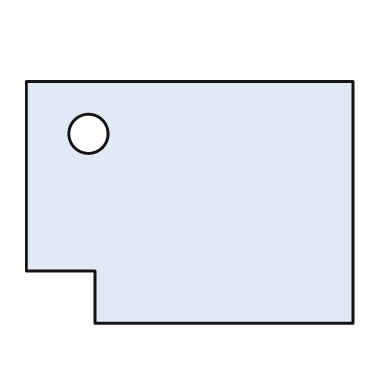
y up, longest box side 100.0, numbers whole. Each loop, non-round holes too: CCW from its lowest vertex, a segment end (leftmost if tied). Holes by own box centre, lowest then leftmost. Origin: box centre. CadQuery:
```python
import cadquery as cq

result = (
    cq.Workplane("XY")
    .moveTo(-29.0, -37.0)
    .lineTo(50.0, -37.0)
    .lineTo(50.0, 37.0)
    .lineTo(-50.0, 37.0)
    .lineTo(-50.0, -21.0)
    .lineTo(-29.0, -21.0)
    .close()
    .moveTo(-31.0, 21.0)
    .circle(6.0)
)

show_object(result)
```